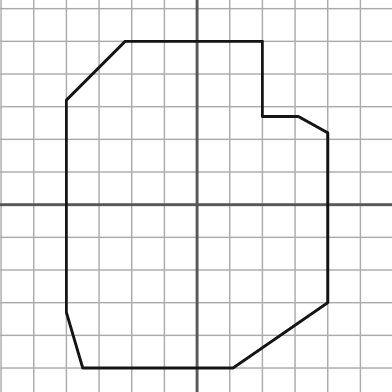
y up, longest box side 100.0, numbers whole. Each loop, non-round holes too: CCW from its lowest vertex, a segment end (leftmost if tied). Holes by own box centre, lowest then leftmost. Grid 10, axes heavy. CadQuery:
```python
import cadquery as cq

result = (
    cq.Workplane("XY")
    .moveTo(-35.0, -50.0)
    .lineTo(11.0, -50.0)
    .lineTo(40.0, -30.0)
    .lineTo(40.0, 22.0)
    .lineTo(31.0, 27.0)
    .lineTo(20.0, 27.0)
    .lineTo(20.0, 50.0)
    .lineTo(-22.0, 50.0)
    .lineTo(-40.0, 32.0)
    .lineTo(-40.0, -33.0)
    .close()
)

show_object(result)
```